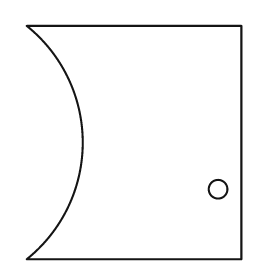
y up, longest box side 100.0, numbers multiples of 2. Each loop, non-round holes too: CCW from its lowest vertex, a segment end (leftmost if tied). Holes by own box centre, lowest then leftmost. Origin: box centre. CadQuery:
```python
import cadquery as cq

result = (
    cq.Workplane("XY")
    .moveTo(-46.0, -50.0)
    .lineTo(46.0, -50.0)
    .lineTo(46.0, 50.0)
    .lineTo(-46.0, 50.0)
    .threePointArc((-22.0, 0.0), (-46.0, -50.0))
    .close()
    .moveTo(36.0, -20.0)
    .circle(4.0)
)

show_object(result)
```